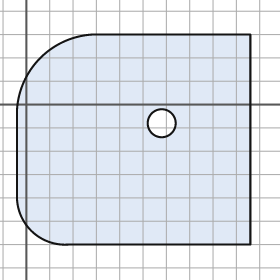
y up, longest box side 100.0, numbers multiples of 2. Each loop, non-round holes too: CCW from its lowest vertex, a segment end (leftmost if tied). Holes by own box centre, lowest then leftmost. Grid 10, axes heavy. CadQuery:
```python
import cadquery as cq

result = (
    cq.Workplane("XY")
    .moveTo(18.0, -60.0)
    .lineTo(96.0, -60.0)
    .lineTo(96.0, 30.0)
    .lineTo(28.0, 30.0)
    .threePointArc((6.0, 20.0), (-4.0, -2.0))
    .lineTo(-4.0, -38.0)
    .threePointArc((2.0, -54.0), (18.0, -60.0))
    .close()
    .moveTo(58.0, -8.0)
    .circle(6.0)
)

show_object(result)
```